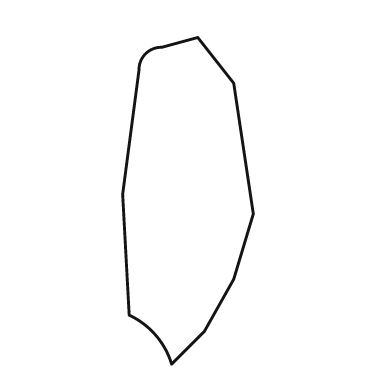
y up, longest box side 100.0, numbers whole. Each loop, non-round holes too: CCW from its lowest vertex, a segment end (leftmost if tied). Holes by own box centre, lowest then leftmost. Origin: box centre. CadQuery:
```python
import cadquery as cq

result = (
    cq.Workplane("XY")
    .moveTo(-5.0, -50.0)
    .lineTo(5.0, -40.0)
    .lineTo(14.0, -24.0)
    .lineTo(20.0, -4.0)
    .lineTo(14.0, 36.0)
    .lineTo(3.0, 50.0)
    .lineTo(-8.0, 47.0)
    .threePointArc((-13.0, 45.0), (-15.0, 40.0))
    .lineTo(-20.0, 2.0)
    .lineTo(-18.0, -35.0)
    .threePointArc((-10.0, -41.0), (-5.0, -50.0))
    .close()
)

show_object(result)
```